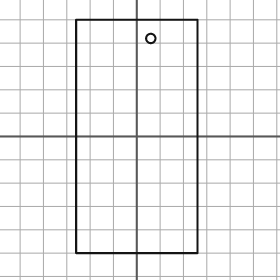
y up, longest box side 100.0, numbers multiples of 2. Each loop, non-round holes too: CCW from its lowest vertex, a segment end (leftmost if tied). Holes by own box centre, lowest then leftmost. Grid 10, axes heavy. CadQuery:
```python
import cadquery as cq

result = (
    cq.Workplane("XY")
    .moveTo(-26.0, -50.0)
    .lineTo(26.0, -50.0)
    .lineTo(26.0, 50.0)
    .lineTo(-26.0, 50.0)
    .close()
    .moveTo(6.0, 42.0)
    .circle(2.0)
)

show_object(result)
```